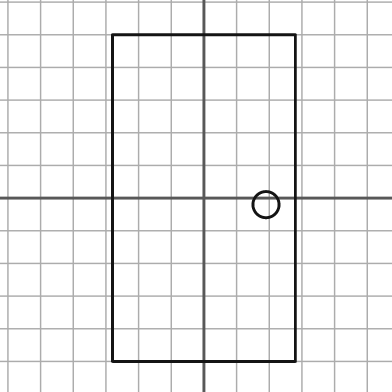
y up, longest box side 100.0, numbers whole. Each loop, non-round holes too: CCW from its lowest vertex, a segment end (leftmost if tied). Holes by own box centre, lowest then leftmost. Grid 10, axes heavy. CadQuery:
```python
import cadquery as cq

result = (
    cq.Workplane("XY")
    .moveTo(-28.0, -50.0)
    .lineTo(28.0, -50.0)
    .lineTo(28.0, 50.0)
    .lineTo(-28.0, 50.0)
    .close()
    .moveTo(19.0, -2.0)
    .circle(4.0)
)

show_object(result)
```